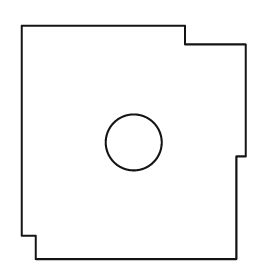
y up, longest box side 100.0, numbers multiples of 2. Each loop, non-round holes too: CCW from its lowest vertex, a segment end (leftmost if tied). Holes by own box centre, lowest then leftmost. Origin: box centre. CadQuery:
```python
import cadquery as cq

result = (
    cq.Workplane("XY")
    .moveTo(-42.0, -50.0)
    .lineTo(44.0, -50.0)
    .lineTo(44.0, -6.0)
    .lineTo(48.0, -6.0)
    .lineTo(48.0, 42.0)
    .lineTo(22.0, 42.0)
    .lineTo(22.0, 50.0)
    .lineTo(-48.0, 50.0)
    .lineTo(-48.0, -40.0)
    .lineTo(-42.0, -40.0)
    .close()
    .moveTo(0.0, 0.0)
    .circle(12.0)
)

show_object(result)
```